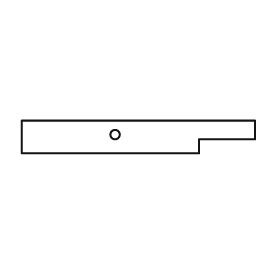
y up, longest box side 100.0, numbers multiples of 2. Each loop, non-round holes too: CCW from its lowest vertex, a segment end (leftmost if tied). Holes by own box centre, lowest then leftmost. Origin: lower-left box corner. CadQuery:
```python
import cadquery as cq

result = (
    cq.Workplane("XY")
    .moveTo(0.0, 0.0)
    .lineTo(76.0, 0.0)
    .lineTo(76.0, 6.0)
    .lineTo(100.0, 6.0)
    .lineTo(100.0, 14.0)
    .lineTo(0.0, 14.0)
    .close()
    .moveTo(40.0, 8.0)
    .circle(2.0)
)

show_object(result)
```